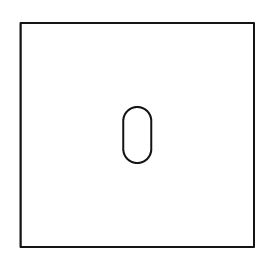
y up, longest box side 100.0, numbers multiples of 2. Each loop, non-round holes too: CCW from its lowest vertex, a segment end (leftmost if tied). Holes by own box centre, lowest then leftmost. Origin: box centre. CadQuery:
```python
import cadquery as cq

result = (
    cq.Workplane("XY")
    .moveTo(-50.0, -48.0)
    .lineTo(50.0, -48.0)
    .lineTo(50.0, 48.0)
    .lineTo(-50.0, 48.0)
    .close()
    .moveTo(-6.0, -6.0)
    .threePointArc((0.0, -12.0), (6.0, -6.0))
    .lineTo(6.0, 6.0)
    .threePointArc((0.0, 12.0), (-6.0, 6.0))
    .close()
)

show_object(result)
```